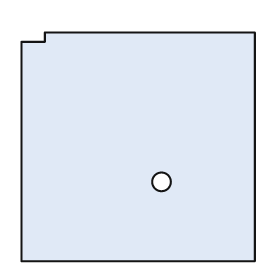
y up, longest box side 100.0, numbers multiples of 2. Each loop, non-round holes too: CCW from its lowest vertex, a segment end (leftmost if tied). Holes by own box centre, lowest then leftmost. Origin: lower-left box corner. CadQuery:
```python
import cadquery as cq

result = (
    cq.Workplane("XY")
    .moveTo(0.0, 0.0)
    .lineTo(100.0, 0.0)
    .lineTo(100.0, 98.0)
    .lineTo(10.0, 98.0)
    .lineTo(10.0, 94.0)
    .lineTo(0.0, 94.0)
    .close()
    .moveTo(60.0, 34.0)
    .circle(4.0)
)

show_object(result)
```